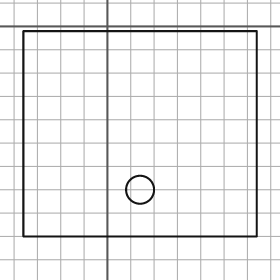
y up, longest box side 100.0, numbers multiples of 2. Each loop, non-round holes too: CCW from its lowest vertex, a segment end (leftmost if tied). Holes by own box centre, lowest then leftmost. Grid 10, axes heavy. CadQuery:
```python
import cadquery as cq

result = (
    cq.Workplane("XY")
    .moveTo(-36.0, -90.0)
    .lineTo(64.0, -90.0)
    .lineTo(64.0, -2.0)
    .lineTo(-36.0, -2.0)
    .close()
    .moveTo(14.0, -70.0)
    .circle(6.0)
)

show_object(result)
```